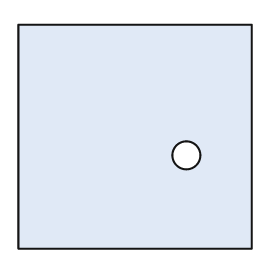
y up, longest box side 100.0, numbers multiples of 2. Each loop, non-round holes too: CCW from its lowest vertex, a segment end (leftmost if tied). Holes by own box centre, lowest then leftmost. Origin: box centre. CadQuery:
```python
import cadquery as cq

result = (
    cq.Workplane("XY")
    .moveTo(-50.0, -48.0)
    .lineTo(50.0, -48.0)
    .lineTo(50.0, 48.0)
    .lineTo(-50.0, 48.0)
    .close()
    .moveTo(22.0, -8.0)
    .circle(6.0)
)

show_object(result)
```